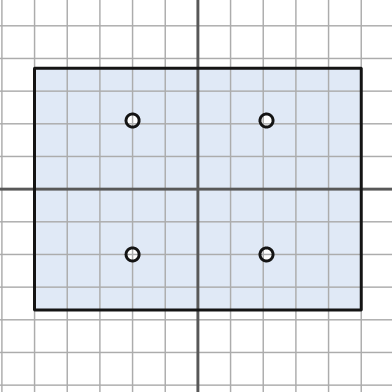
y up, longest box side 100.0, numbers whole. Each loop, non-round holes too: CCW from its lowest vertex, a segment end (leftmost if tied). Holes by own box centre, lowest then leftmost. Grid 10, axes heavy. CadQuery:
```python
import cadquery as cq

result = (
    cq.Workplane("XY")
    .moveTo(-50.0, -37.0)
    .lineTo(50.0, -37.0)
    .lineTo(50.0, 37.0)
    .lineTo(-50.0, 37.0)
    .close()
    .moveTo(-20.0, -20.0)
    .circle(2.0)
    .moveTo(21.0, -20.0)
    .circle(2.0)
    .moveTo(-20.0, 21.0)
    .circle(2.0)
    .moveTo(21.0, 21.0)
    .circle(2.0)
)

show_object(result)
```